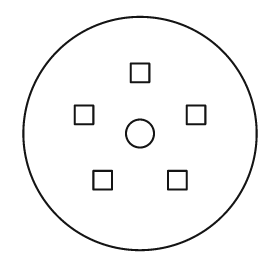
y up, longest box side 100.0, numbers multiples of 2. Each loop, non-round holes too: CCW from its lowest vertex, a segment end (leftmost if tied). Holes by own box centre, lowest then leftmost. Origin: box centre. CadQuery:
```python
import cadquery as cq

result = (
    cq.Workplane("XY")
    .moveTo(0.0, 0.0)
    .circle(50.0)
    .moveTo(-20.0, -24.0)
    .lineTo(-12.0, -24.0)
    .lineTo(-12.0, -16.0)
    .lineTo(-20.0, -16.0)
    .close()
    .moveTo(12.0, -24.0)
    .lineTo(20.0, -24.0)
    .lineTo(20.0, -16.0)
    .lineTo(12.0, -16.0)
    .close()
    .moveTo(0.0, 0.0)
    .circle(6.0)
    .moveTo(-28.0, 4.0)
    .lineTo(-20.0, 4.0)
    .lineTo(-20.0, 12.0)
    .lineTo(-28.0, 12.0)
    .close()
    .moveTo(20.0, 4.0)
    .lineTo(28.0, 4.0)
    .lineTo(28.0, 12.0)
    .lineTo(20.0, 12.0)
    .close()
    .moveTo(-4.0, 22.0)
    .lineTo(4.0, 22.0)
    .lineTo(4.0, 30.0)
    .lineTo(-4.0, 30.0)
    .close()
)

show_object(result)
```